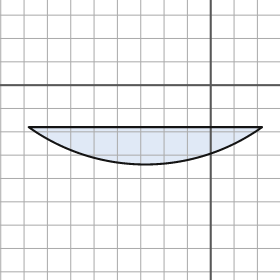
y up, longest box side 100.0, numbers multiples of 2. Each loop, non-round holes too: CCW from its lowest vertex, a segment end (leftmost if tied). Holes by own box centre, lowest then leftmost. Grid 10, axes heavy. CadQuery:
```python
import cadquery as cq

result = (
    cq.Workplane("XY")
    .moveTo(-78.0, -18.0)
    .threePointArc((-28.0, -34.0), (22.0, -18.0))
    .close()
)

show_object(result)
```